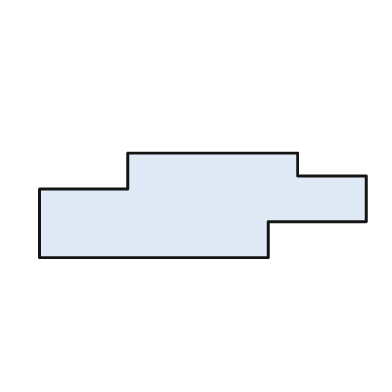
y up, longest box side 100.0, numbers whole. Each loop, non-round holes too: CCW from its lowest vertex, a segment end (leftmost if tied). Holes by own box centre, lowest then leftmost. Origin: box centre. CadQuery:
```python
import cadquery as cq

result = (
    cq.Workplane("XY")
    .moveTo(-50.0, -16.0)
    .lineTo(20.0, -16.0)
    .lineTo(20.0, -5.0)
    .lineTo(50.0, -5.0)
    .lineTo(50.0, 9.0)
    .lineTo(29.0, 9.0)
    .lineTo(29.0, 16.0)
    .lineTo(-23.0, 16.0)
    .lineTo(-23.0, 5.0)
    .lineTo(-50.0, 5.0)
    .close()
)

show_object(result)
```